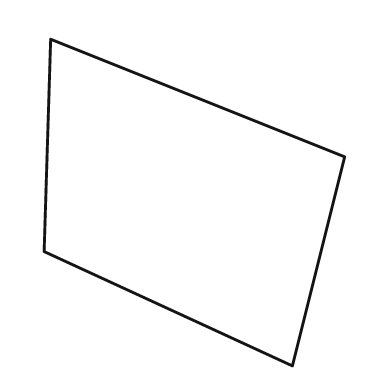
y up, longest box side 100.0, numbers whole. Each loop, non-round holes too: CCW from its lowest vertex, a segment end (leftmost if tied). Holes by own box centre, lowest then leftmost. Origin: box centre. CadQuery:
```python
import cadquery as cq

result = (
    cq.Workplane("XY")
    .moveTo(30.0, -50.0)
    .lineTo(46.0, 14.0)
    .lineTo(-44.0, 50.0)
    .lineTo(-46.0, -15.0)
    .close()
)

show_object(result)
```